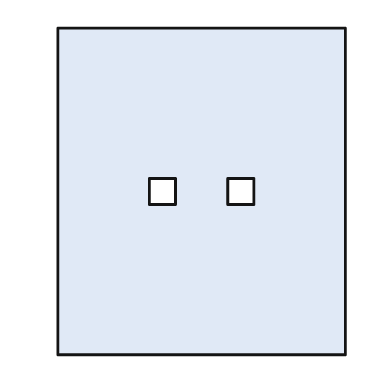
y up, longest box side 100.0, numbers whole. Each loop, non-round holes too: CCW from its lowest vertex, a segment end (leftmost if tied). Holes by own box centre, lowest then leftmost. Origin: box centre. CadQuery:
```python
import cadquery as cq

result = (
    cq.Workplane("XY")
    .moveTo(-44.0, -50.0)
    .lineTo(44.0, -50.0)
    .lineTo(44.0, 50.0)
    .lineTo(-44.0, 50.0)
    .close()
    .moveTo(-16.0, -4.0)
    .lineTo(-8.0, -4.0)
    .lineTo(-8.0, 4.0)
    .lineTo(-16.0, 4.0)
    .close()
    .moveTo(8.0, -4.0)
    .lineTo(16.0, -4.0)
    .lineTo(16.0, 4.0)
    .lineTo(8.0, 4.0)
    .close()
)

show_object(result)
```